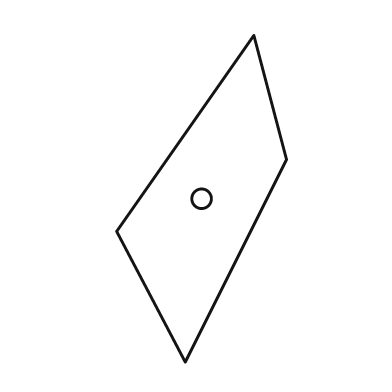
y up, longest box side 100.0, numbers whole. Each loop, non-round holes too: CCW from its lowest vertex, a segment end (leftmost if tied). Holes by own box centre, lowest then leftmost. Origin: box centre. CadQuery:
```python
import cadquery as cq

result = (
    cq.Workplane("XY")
    .moveTo(-5.0, -50.0)
    .lineTo(26.0, 12.0)
    .lineTo(16.0, 50.0)
    .lineTo(-26.0, -10.0)
    .close()
    .moveTo(0.0, 0.0)
    .circle(3.0)
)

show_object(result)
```